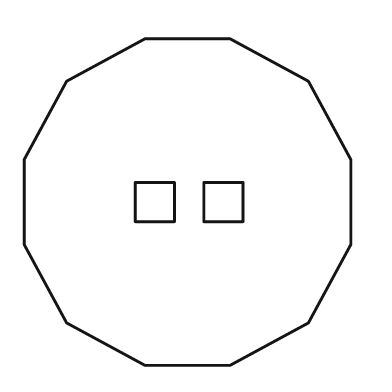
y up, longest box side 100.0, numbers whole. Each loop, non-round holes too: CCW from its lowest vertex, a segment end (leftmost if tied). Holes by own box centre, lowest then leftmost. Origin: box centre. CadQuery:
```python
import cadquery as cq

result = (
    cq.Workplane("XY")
    .moveTo(-13.0, -50.0)
    .lineTo(13.0, -50.0)
    .lineTo(37.0, -37.0)
    .lineTo(50.0, -13.0)
    .lineTo(50.0, 13.0)
    .lineTo(37.0, 37.0)
    .lineTo(13.0, 50.0)
    .lineTo(-13.0, 50.0)
    .lineTo(-37.0, 37.0)
    .lineTo(-50.0, 13.0)
    .lineTo(-50.0, -13.0)
    .lineTo(-37.0, -37.0)
    .close()
    .moveTo(-16.0, -6.0)
    .lineTo(-4.0, -6.0)
    .lineTo(-4.0, 6.0)
    .lineTo(-16.0, 6.0)
    .close()
    .moveTo(5.0, -6.0)
    .lineTo(17.0, -6.0)
    .lineTo(17.0, 6.0)
    .lineTo(5.0, 6.0)
    .close()
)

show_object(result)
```